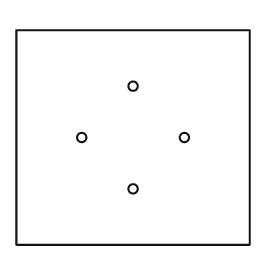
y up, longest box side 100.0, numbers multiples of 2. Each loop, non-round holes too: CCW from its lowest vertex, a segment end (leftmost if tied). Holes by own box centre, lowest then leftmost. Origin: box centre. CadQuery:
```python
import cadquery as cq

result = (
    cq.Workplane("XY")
    .moveTo(-50.0, -46.0)
    .lineTo(50.0, -46.0)
    .lineTo(50.0, 46.0)
    .lineTo(-50.0, 46.0)
    .close()
    .moveTo(0.0, -22.0)
    .circle(2.0)
    .moveTo(-22.0, 0.0)
    .circle(2.0)
    .moveTo(22.0, 0.0)
    .circle(2.0)
    .moveTo(0.0, 22.0)
    .circle(2.0)
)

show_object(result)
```